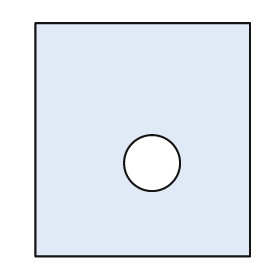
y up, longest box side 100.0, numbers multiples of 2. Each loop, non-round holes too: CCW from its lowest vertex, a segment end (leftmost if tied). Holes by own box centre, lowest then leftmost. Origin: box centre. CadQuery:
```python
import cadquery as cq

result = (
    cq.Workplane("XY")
    .moveTo(-46.0, -50.0)
    .lineTo(46.0, -50.0)
    .lineTo(46.0, 50.0)
    .lineTo(-46.0, 50.0)
    .close()
    .moveTo(4.0, -10.0)
    .circle(12.0)
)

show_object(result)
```